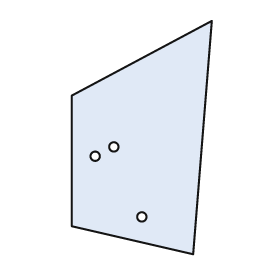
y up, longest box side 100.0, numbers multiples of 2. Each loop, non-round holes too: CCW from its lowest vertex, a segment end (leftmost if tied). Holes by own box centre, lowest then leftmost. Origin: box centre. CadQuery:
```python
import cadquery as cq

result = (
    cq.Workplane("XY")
    .moveTo(22.0, -50.0)
    .lineTo(30.0, 50.0)
    .lineTo(-30.0, 18.0)
    .lineTo(-30.0, -38.0)
    .close()
    .moveTo(0.0, -34.0)
    .circle(2.0)
    .moveTo(-20.0, -8.0)
    .circle(2.0)
    .moveTo(-12.0, -4.0)
    .circle(2.0)
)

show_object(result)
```